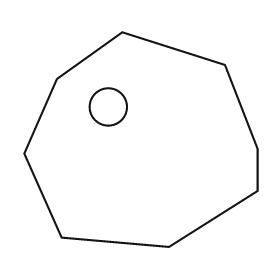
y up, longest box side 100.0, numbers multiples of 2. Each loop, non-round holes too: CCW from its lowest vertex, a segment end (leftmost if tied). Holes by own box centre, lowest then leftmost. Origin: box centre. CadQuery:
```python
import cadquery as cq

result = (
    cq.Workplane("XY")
    .moveTo(12.0, -46.0)
    .lineTo(50.0, -22.0)
    .lineTo(50.0, -4.0)
    .lineTo(36.0, 32.0)
    .lineTo(-8.0, 46.0)
    .lineTo(-36.0, 26.0)
    .lineTo(-50.0, -6.0)
    .lineTo(-34.0, -42.0)
    .close()
    .moveTo(-14.0, 14.0)
    .circle(8.0)
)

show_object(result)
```